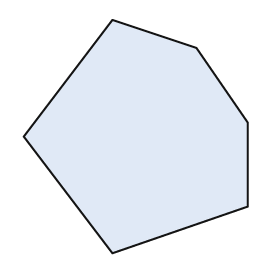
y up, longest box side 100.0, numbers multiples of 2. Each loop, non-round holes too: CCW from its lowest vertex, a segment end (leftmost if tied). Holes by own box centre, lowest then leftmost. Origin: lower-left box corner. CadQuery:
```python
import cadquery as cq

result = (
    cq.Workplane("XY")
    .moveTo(38.0, 0.0)
    .lineTo(96.0, 20.0)
    .lineTo(96.0, 56.0)
    .lineTo(74.0, 88.0)
    .lineTo(38.0, 100.0)
    .lineTo(0.0, 50.0)
    .close()
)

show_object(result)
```